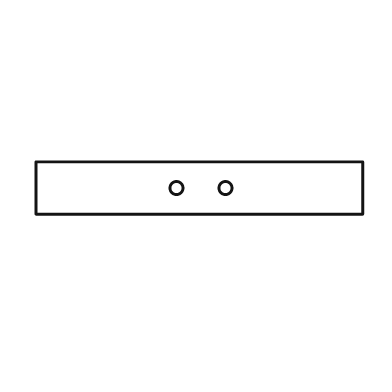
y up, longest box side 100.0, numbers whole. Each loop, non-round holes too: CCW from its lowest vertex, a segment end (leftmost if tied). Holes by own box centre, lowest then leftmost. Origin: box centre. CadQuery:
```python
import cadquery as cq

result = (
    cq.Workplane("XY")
    .moveTo(-50.0, -8.0)
    .lineTo(50.0, -8.0)
    .lineTo(50.0, 8.0)
    .lineTo(-50.0, 8.0)
    .close()
    .moveTo(-7.0, 0.0)
    .circle(2.0)
    .moveTo(8.0, 0.0)
    .circle(2.0)
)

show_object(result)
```